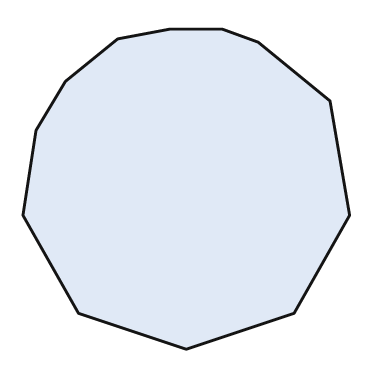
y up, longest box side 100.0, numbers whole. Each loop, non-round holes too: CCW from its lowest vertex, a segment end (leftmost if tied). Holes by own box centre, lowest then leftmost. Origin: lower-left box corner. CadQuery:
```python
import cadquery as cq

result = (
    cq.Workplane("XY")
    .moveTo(50.0, 0.0)
    .lineTo(83.0, 11.0)
    .lineTo(100.0, 41.0)
    .lineTo(94.0, 76.0)
    .lineTo(72.0, 94.0)
    .lineTo(61.0, 98.0)
    .lineTo(45.0, 98.0)
    .lineTo(29.0, 95.0)
    .lineTo(13.0, 82.0)
    .lineTo(4.0, 67.0)
    .lineTo(0.0, 41.0)
    .lineTo(17.0, 11.0)
    .close()
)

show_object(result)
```